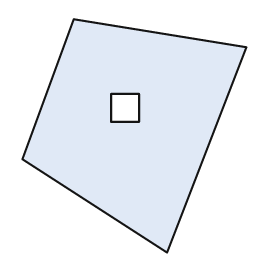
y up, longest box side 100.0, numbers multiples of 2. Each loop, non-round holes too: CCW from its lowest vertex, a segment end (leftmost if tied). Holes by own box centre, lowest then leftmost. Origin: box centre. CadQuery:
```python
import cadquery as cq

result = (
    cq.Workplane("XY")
    .moveTo(14.0, -50.0)
    .lineTo(48.0, 38.0)
    .lineTo(-26.0, 50.0)
    .lineTo(-48.0, -10.0)
    .close()
    .moveTo(-10.0, 6.0)
    .lineTo(2.0, 6.0)
    .lineTo(2.0, 18.0)
    .lineTo(-10.0, 18.0)
    .close()
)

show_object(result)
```